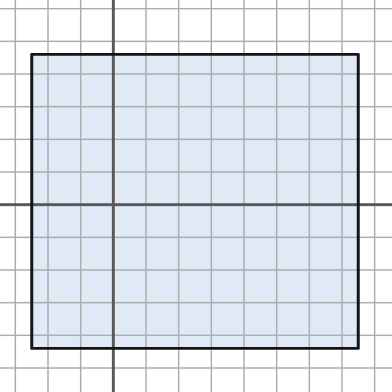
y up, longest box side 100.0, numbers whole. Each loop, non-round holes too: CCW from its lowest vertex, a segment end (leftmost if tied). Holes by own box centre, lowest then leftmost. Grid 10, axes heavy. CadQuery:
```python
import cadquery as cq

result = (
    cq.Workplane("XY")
    .moveTo(-25.0, -44.0)
    .lineTo(75.0, -44.0)
    .lineTo(75.0, 46.0)
    .lineTo(-25.0, 46.0)
    .close()
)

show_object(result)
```